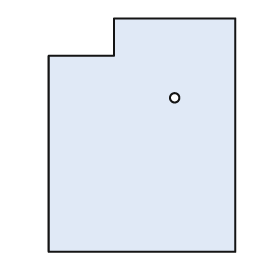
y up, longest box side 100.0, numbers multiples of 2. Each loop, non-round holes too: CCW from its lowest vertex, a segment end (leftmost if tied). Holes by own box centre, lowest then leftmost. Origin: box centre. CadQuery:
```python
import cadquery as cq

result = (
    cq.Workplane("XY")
    .moveTo(-40.0, -50.0)
    .lineTo(40.0, -50.0)
    .lineTo(40.0, 50.0)
    .lineTo(-12.0, 50.0)
    .lineTo(-12.0, 34.0)
    .lineTo(-40.0, 34.0)
    .close()
    .moveTo(14.0, 16.0)
    .circle(2.0)
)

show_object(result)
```